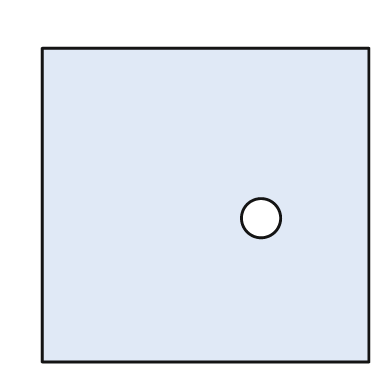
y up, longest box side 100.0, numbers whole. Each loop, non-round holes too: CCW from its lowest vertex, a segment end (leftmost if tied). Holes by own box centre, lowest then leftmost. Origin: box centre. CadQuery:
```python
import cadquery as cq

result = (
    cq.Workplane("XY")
    .moveTo(-50.0, -48.0)
    .lineTo(50.0, -48.0)
    .lineTo(50.0, 48.0)
    .lineTo(-50.0, 48.0)
    .close()
    .moveTo(17.0, -4.0)
    .circle(6.0)
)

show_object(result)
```